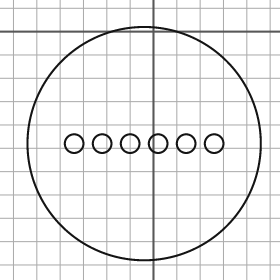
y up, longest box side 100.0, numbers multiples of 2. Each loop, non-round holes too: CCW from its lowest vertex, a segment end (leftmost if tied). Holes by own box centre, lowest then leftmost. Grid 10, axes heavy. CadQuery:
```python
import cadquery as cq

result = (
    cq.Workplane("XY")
    .moveTo(-4.0, -48.0)
    .circle(50.0)
    .moveTo(-34.0, -48.0)
    .circle(4.0)
    .moveTo(-22.0, -48.0)
    .circle(4.0)
    .moveTo(-10.0, -48.0)
    .circle(4.0)
    .moveTo(2.0, -48.0)
    .circle(4.0)
    .moveTo(14.0, -48.0)
    .circle(4.0)
    .moveTo(26.0, -48.0)
    .circle(4.0)
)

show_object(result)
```